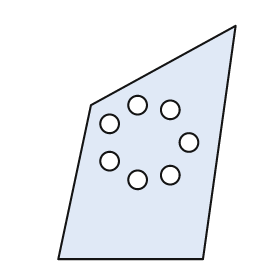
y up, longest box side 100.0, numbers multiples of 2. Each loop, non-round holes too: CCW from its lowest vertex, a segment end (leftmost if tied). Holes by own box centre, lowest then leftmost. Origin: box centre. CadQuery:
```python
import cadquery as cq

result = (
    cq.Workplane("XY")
    .moveTo(-38.0, -50.0)
    .lineTo(24.0, -50.0)
    .lineTo(38.0, 50.0)
    .lineTo(-24.0, 16.0)
    .close()
    .moveTo(-4.0, -16.0)
    .circle(4.0)
    .moveTo(10.0, -14.0)
    .circle(4.0)
    .moveTo(-16.0, -8.0)
    .circle(4.0)
    .moveTo(18.0, 0.0)
    .circle(4.0)
    .moveTo(-16.0, 8.0)
    .circle(4.0)
    .moveTo(10.0, 14.0)
    .circle(4.0)
    .moveTo(-4.0, 16.0)
    .circle(4.0)
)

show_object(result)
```